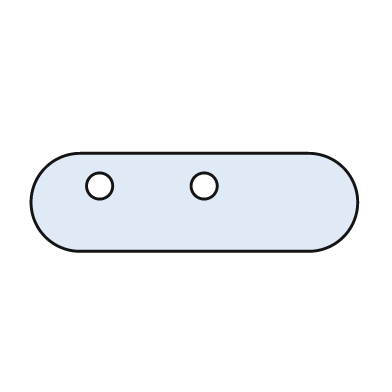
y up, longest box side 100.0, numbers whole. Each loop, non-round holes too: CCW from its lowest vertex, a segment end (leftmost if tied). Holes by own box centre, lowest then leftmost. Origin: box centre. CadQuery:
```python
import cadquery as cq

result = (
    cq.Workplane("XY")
    .moveTo(-35.0, -15.0)
    .lineTo(35.0, -15.0)
    .threePointArc((50.0, 0.0), (35.0, 15.0))
    .lineTo(-35.0, 15.0)
    .threePointArc((-50.0, 0.0), (-35.0, -15.0))
    .close()
    .moveTo(-29.0, 5.0)
    .circle(4.0)
    .moveTo(3.0, 5.0)
    .circle(4.0)
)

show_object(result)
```